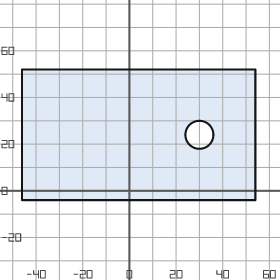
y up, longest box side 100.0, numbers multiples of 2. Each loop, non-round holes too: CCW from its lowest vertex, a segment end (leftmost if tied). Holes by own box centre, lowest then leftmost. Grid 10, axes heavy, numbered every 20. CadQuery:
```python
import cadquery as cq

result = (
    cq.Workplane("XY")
    .moveTo(-46.0, -4.0)
    .lineTo(54.0, -4.0)
    .lineTo(54.0, 52.0)
    .lineTo(-46.0, 52.0)
    .close()
    .moveTo(30.0, 24.0)
    .circle(6.0)
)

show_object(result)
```